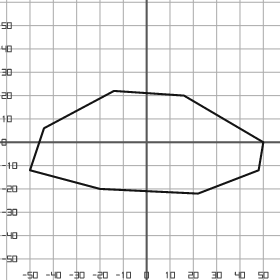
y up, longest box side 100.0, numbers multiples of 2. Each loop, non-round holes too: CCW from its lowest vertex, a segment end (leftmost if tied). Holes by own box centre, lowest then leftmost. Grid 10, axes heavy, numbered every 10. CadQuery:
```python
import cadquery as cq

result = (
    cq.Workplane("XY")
    .moveTo(22.0, -22.0)
    .lineTo(48.0, -12.0)
    .lineTo(50.0, 0.0)
    .lineTo(16.0, 20.0)
    .lineTo(-14.0, 22.0)
    .lineTo(-44.0, 6.0)
    .lineTo(-50.0, -12.0)
    .lineTo(-20.0, -20.0)
    .close()
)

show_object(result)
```